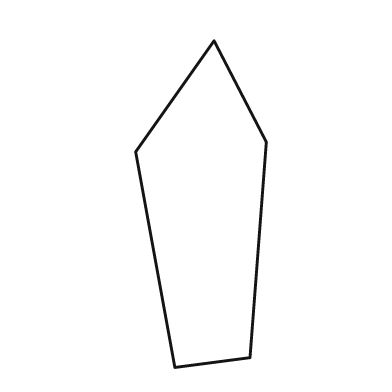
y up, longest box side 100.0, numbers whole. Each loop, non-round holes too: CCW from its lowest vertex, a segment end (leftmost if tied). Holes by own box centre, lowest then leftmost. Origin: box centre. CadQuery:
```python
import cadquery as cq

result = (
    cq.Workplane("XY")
    .moveTo(-8.0, -50.0)
    .lineTo(15.0, -47.0)
    .lineTo(20.0, 19.0)
    .lineTo(4.0, 50.0)
    .lineTo(-20.0, 16.0)
    .close()
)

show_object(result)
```